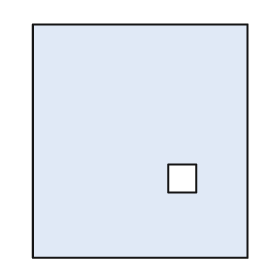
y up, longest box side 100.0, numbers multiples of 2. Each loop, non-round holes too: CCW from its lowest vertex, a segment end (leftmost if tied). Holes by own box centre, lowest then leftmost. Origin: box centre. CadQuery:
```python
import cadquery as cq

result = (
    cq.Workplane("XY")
    .moveTo(-46.0, -50.0)
    .lineTo(46.0, -50.0)
    .lineTo(46.0, 50.0)
    .lineTo(-46.0, 50.0)
    .close()
    .moveTo(12.0, -22.0)
    .lineTo(24.0, -22.0)
    .lineTo(24.0, -10.0)
    .lineTo(12.0, -10.0)
    .close()
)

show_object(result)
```